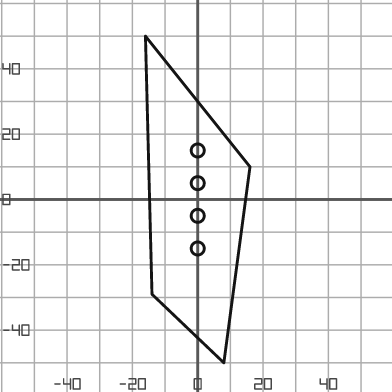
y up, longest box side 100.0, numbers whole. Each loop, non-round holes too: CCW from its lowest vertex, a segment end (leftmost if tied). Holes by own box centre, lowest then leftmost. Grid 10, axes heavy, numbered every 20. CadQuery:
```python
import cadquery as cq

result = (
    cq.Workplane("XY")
    .moveTo(8.0, -50.0)
    .lineTo(16.0, 10.0)
    .lineTo(-16.0, 50.0)
    .lineTo(-14.0, -29.0)
    .close()
    .moveTo(0.0, -15.0)
    .circle(2.0)
    .moveTo(0.0, -5.0)
    .circle(2.0)
    .moveTo(0.0, 5.0)
    .circle(2.0)
    .moveTo(0.0, 15.0)
    .circle(2.0)
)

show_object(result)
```